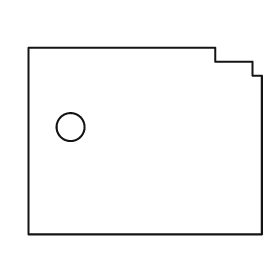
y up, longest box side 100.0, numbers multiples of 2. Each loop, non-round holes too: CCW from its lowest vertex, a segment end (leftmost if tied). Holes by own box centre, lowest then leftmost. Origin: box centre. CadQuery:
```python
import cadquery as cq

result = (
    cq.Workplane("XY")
    .moveTo(-50.0, -40.0)
    .lineTo(50.0, -40.0)
    .lineTo(50.0, 28.0)
    .lineTo(46.0, 28.0)
    .lineTo(46.0, 34.0)
    .lineTo(30.0, 34.0)
    .lineTo(30.0, 40.0)
    .lineTo(-50.0, 40.0)
    .close()
    .moveTo(-32.0, 6.0)
    .circle(6.0)
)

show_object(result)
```